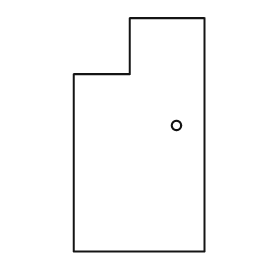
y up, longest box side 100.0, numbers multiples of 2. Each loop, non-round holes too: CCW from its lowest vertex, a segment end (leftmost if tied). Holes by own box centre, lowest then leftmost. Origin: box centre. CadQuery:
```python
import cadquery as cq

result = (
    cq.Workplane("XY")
    .moveTo(-28.0, -50.0)
    .lineTo(28.0, -50.0)
    .lineTo(28.0, 50.0)
    .lineTo(-4.0, 50.0)
    .lineTo(-4.0, 26.0)
    .lineTo(-28.0, 26.0)
    .close()
    .moveTo(16.0, 4.0)
    .circle(2.0)
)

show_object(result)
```